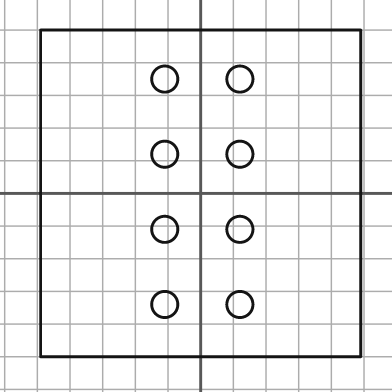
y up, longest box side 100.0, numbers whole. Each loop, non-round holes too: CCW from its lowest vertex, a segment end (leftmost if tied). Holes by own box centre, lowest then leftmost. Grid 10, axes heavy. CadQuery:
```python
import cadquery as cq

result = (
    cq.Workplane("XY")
    .moveTo(-49.0, -50.0)
    .lineTo(49.0, -50.0)
    .lineTo(49.0, 50.0)
    .lineTo(-49.0, 50.0)
    .close()
    .moveTo(-11.0, -34.0)
    .circle(4.0)
    .moveTo(12.0, -34.0)
    .circle(4.0)
    .moveTo(-11.0, -11.0)
    .circle(4.0)
    .moveTo(12.0, -11.0)
    .circle(4.0)
    .moveTo(-11.0, 12.0)
    .circle(4.0)
    .moveTo(12.0, 12.0)
    .circle(4.0)
    .moveTo(-11.0, 35.0)
    .circle(4.0)
    .moveTo(12.0, 35.0)
    .circle(4.0)
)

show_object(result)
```